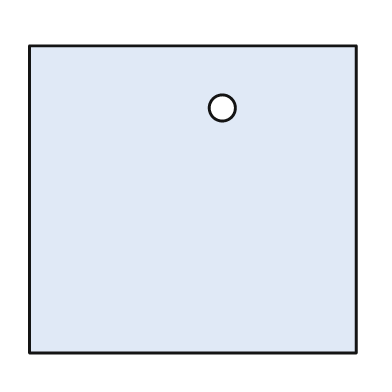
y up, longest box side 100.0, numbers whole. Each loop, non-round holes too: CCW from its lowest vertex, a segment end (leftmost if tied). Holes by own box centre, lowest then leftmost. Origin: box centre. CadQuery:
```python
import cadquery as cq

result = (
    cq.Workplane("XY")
    .moveTo(-50.0, -47.0)
    .lineTo(50.0, -47.0)
    .lineTo(50.0, 47.0)
    .lineTo(-50.0, 47.0)
    .close()
    .moveTo(9.0, 28.0)
    .circle(4.0)
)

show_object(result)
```